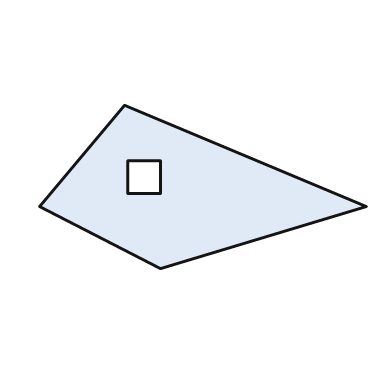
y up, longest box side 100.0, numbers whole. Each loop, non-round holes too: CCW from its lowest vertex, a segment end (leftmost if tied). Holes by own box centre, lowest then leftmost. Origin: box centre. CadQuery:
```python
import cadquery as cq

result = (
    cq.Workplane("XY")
    .moveTo(-13.0, -25.0)
    .lineTo(50.0, -6.0)
    .lineTo(-24.0, 25.0)
    .lineTo(-50.0, -6.0)
    .close()
    .moveTo(-23.0, -2.0)
    .lineTo(-13.0, -2.0)
    .lineTo(-13.0, 8.0)
    .lineTo(-23.0, 8.0)
    .close()
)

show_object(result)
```